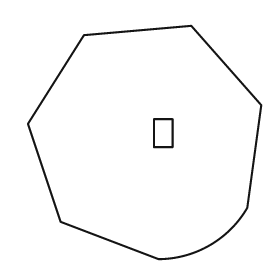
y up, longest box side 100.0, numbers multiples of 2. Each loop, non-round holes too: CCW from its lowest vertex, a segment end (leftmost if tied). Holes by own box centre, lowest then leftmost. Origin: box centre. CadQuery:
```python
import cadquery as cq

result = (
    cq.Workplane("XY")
    .moveTo(6.0, -50.0)
    .threePointArc((28.0, -44.0), (44.0, -28.0))
    .lineTo(50.0, 16.0)
    .lineTo(20.0, 50.0)
    .lineTo(-26.0, 46.0)
    .lineTo(-50.0, 8.0)
    .lineTo(-36.0, -34.0)
    .close()
    .moveTo(4.0, -2.0)
    .lineTo(12.0, -2.0)
    .lineTo(12.0, 10.0)
    .lineTo(4.0, 10.0)
    .close()
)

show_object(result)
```